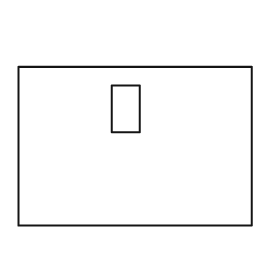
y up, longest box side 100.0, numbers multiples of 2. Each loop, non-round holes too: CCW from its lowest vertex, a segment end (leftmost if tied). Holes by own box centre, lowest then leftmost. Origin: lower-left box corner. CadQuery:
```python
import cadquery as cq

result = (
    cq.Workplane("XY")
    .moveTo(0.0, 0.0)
    .lineTo(100.0, 0.0)
    .lineTo(100.0, 68.0)
    .lineTo(0.0, 68.0)
    .close()
    .moveTo(40.0, 40.0)
    .lineTo(52.0, 40.0)
    .lineTo(52.0, 60.0)
    .lineTo(40.0, 60.0)
    .close()
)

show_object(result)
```